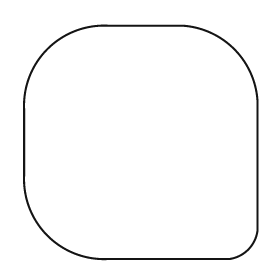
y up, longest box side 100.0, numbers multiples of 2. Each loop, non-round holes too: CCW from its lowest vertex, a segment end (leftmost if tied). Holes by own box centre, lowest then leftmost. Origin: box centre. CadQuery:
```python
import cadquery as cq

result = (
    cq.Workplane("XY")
    .moveTo(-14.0, -50.0)
    .lineTo(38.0, -50.0)
    .threePointArc((46.0, -46.0), (50.0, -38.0))
    .lineTo(50.0, 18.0)
    .threePointArc((40.0, 40.0), (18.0, 50.0))
    .lineTo(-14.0, 50.0)
    .threePointArc((-40.0, 40.0), (-50.0, 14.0))
    .lineTo(-50.0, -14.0)
    .threePointArc((-40.0, -40.0), (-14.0, -50.0))
    .close()
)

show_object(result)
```